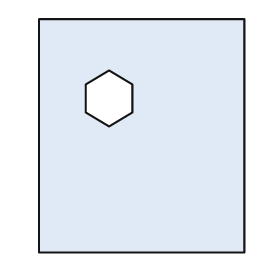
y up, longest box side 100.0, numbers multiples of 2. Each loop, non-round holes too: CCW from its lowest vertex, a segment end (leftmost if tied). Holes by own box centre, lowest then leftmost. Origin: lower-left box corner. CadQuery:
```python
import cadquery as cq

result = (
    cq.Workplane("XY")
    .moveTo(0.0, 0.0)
    .lineTo(88.0, 0.0)
    .lineTo(88.0, 100.0)
    .lineTo(0.0, 100.0)
    .close()
    .moveTo(30.0, 54.0)
    .lineTo(40.0, 60.0)
    .lineTo(40.0, 72.0)
    .lineTo(30.0, 78.0)
    .lineTo(20.0, 72.0)
    .lineTo(20.0, 60.0)
    .close()
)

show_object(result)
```